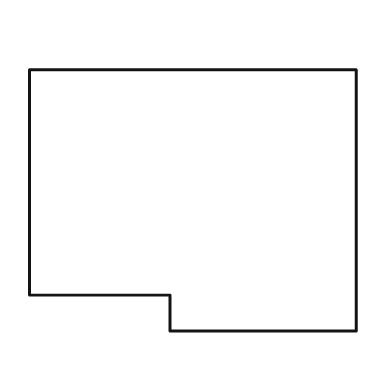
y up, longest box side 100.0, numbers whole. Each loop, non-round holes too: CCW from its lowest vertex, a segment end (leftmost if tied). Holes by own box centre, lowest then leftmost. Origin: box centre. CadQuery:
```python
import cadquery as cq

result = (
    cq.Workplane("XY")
    .moveTo(-7.0, -40.0)
    .lineTo(50.0, -40.0)
    .lineTo(50.0, 40.0)
    .lineTo(-50.0, 40.0)
    .lineTo(-50.0, -29.0)
    .lineTo(-7.0, -29.0)
    .close()
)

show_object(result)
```